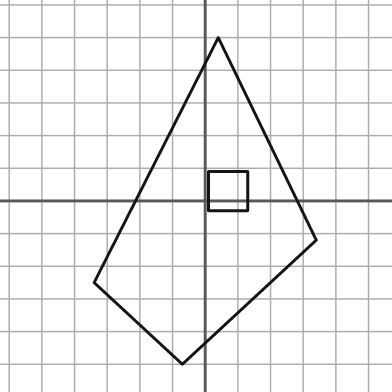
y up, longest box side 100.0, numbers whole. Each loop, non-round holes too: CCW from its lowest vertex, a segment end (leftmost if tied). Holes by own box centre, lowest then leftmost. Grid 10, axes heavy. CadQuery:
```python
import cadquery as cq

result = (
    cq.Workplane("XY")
    .moveTo(-7.0, -50.0)
    .lineTo(34.0, -12.0)
    .lineTo(4.0, 50.0)
    .lineTo(-34.0, -25.0)
    .close()
    .moveTo(1.0, -3.0)
    .lineTo(13.0, -3.0)
    .lineTo(13.0, 9.0)
    .lineTo(1.0, 9.0)
    .close()
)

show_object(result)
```